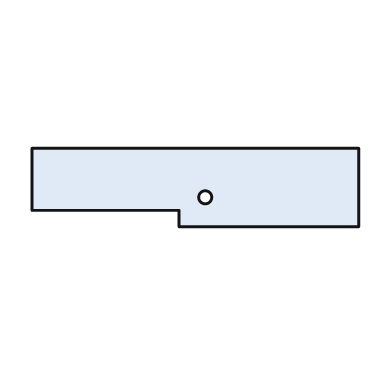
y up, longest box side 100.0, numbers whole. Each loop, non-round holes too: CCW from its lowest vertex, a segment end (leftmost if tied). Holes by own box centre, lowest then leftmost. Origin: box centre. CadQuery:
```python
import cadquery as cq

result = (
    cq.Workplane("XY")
    .moveTo(-5.0, -12.0)
    .lineTo(50.0, -12.0)
    .lineTo(50.0, 12.0)
    .lineTo(-50.0, 12.0)
    .lineTo(-50.0, -7.0)
    .lineTo(-5.0, -7.0)
    .close()
    .moveTo(3.0, -3.0)
    .circle(2.0)
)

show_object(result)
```